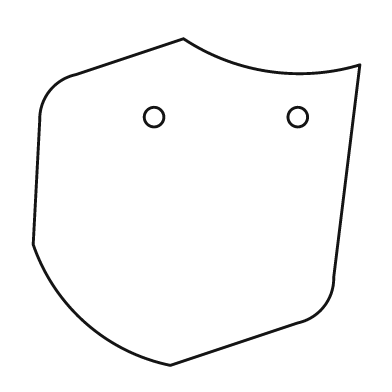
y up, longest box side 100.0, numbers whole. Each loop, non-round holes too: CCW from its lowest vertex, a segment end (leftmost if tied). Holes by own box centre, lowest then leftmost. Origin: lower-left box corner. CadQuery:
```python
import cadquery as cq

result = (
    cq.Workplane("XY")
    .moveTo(42.0, 0.0)
    .lineTo(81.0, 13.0)
    .threePointArc((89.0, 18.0), (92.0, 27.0))
    .lineTo(100.0, 92.0)
    .threePointArc((72.0, 90.0), (46.0, 100.0))
    .lineTo(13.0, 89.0)
    .threePointArc((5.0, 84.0), (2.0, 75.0))
    .lineTo(0.0, 37.0)
    .threePointArc((16.0, 13.0), (42.0, 0.0))
    .close()
    .moveTo(37.0, 76.0)
    .circle(3.0)
    .moveTo(81.0, 76.0)
    .circle(3.0)
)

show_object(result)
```